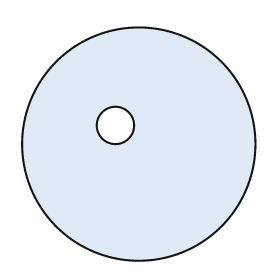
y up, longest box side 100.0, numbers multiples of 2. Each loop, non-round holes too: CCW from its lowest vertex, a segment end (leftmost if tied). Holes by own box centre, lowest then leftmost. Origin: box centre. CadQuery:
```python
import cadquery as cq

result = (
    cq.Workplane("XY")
    .moveTo(0.0, 0.0)
    .circle(50.0)
    .moveTo(-10.0, 8.0)
    .circle(8.0)
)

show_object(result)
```